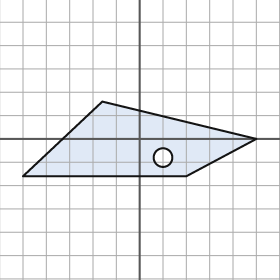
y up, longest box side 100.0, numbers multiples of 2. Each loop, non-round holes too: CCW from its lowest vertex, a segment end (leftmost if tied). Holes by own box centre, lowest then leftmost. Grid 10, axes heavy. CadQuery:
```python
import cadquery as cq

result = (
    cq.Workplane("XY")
    .moveTo(-50.0, -16.0)
    .lineTo(20.0, -16.0)
    .lineTo(50.0, 0.0)
    .lineTo(-16.0, 16.0)
    .close()
    .moveTo(10.0, -8.0)
    .circle(4.0)
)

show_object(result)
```